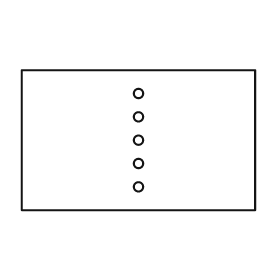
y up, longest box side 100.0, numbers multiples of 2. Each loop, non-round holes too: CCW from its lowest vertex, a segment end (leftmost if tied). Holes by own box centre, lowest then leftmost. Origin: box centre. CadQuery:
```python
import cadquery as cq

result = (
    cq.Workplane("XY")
    .moveTo(-50.0, -30.0)
    .lineTo(50.0, -30.0)
    .lineTo(50.0, 30.0)
    .lineTo(-50.0, 30.0)
    .close()
    .moveTo(0.0, -20.0)
    .circle(2.0)
    .moveTo(0.0, -10.0)
    .circle(2.0)
    .moveTo(0.0, 0.0)
    .circle(2.0)
    .moveTo(0.0, 10.0)
    .circle(2.0)
    .moveTo(0.0, 20.0)
    .circle(2.0)
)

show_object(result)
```